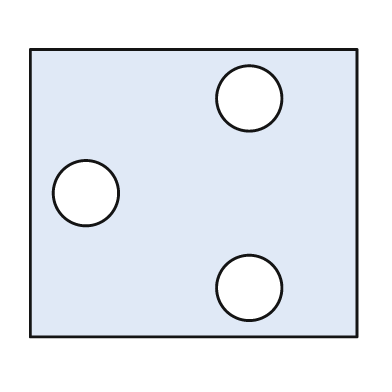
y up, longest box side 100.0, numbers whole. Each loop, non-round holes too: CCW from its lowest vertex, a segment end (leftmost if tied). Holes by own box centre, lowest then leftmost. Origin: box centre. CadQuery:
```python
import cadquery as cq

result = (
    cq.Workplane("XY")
    .moveTo(-50.0, -44.0)
    .lineTo(50.0, -44.0)
    .lineTo(50.0, 44.0)
    .lineTo(-50.0, 44.0)
    .close()
    .moveTo(17.0, -29.0)
    .circle(10.0)
    .moveTo(-33.0, 0.0)
    .circle(10.0)
    .moveTo(17.0, 29.0)
    .circle(10.0)
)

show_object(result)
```